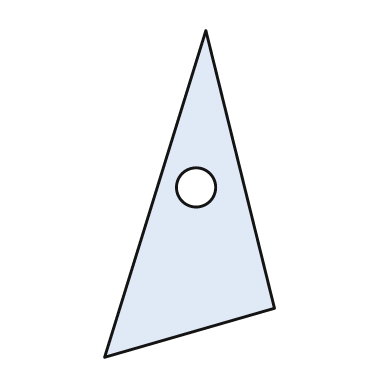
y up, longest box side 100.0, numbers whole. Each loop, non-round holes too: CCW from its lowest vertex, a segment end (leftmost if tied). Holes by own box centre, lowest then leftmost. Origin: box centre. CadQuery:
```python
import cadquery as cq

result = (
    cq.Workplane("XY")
    .moveTo(-26.0, -50.0)
    .lineTo(26.0, -35.0)
    .lineTo(5.0, 50.0)
    .close()
    .moveTo(2.0, 2.0)
    .circle(6.0)
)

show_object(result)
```